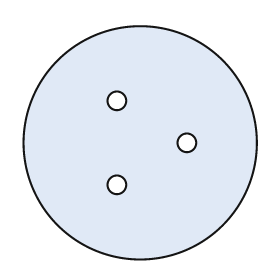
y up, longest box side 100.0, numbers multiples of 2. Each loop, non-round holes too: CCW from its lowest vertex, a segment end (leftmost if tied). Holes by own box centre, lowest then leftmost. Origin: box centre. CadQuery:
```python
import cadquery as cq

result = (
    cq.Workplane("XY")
    .moveTo(0.0, 0.0)
    .circle(50.0)
    .moveTo(-10.0, -18.0)
    .circle(4.0)
    .moveTo(20.0, 0.0)
    .circle(4.0)
    .moveTo(-10.0, 18.0)
    .circle(4.0)
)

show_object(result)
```